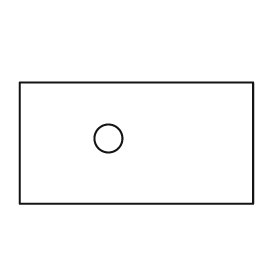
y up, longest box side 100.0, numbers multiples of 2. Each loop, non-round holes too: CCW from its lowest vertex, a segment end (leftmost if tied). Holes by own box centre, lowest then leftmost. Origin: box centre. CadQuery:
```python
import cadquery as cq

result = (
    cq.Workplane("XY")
    .moveTo(-50.0, -26.0)
    .lineTo(50.0, -26.0)
    .lineTo(50.0, 26.0)
    .lineTo(-50.0, 26.0)
    .close()
    .moveTo(-12.0, 2.0)
    .circle(6.0)
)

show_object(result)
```